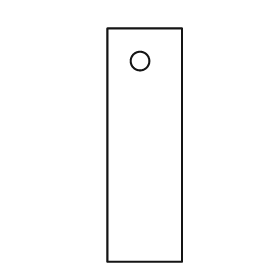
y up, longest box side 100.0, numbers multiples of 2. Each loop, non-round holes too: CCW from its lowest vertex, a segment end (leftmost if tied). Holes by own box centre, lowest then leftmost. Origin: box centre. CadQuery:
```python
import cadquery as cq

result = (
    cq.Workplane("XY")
    .moveTo(-16.0, -50.0)
    .lineTo(16.0, -50.0)
    .lineTo(16.0, 50.0)
    .lineTo(-16.0, 50.0)
    .close()
    .moveTo(-2.0, 36.0)
    .circle(4.0)
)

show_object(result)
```